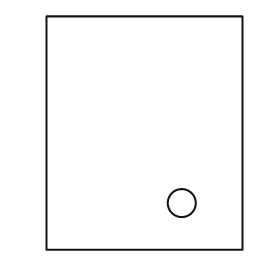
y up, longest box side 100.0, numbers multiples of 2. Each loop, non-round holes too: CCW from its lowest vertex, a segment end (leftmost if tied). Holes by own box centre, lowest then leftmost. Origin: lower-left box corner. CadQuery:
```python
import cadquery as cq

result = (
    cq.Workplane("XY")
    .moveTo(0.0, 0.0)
    .lineTo(84.0, 0.0)
    .lineTo(84.0, 100.0)
    .lineTo(0.0, 100.0)
    .close()
    .moveTo(58.0, 20.0)
    .circle(6.0)
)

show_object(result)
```